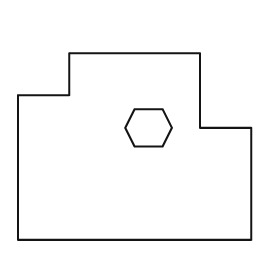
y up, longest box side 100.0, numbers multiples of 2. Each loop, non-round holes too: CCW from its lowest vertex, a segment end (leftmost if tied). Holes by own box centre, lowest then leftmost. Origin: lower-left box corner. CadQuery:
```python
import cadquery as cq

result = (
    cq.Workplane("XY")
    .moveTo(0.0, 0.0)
    .lineTo(100.0, 0.0)
    .lineTo(100.0, 48.0)
    .lineTo(78.0, 48.0)
    .lineTo(78.0, 80.0)
    .lineTo(22.0, 80.0)
    .lineTo(22.0, 62.0)
    .lineTo(0.0, 62.0)
    .close()
    .moveTo(50.0, 40.0)
    .lineTo(62.0, 40.0)
    .lineTo(66.0, 48.0)
    .lineTo(62.0, 56.0)
    .lineTo(50.0, 56.0)
    .lineTo(46.0, 48.0)
    .close()
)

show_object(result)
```